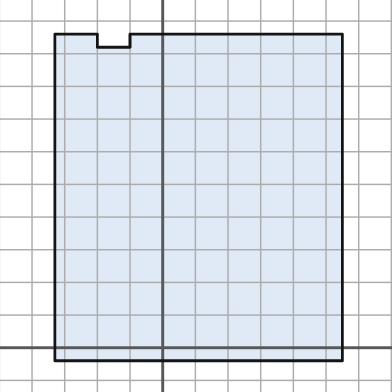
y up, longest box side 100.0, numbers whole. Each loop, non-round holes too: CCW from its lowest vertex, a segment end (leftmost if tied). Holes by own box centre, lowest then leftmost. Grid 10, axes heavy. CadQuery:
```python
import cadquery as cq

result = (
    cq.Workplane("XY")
    .moveTo(-33.0, -4.0)
    .lineTo(55.0, -4.0)
    .lineTo(55.0, 96.0)
    .lineTo(-10.0, 96.0)
    .lineTo(-10.0, 92.0)
    .lineTo(-20.0, 92.0)
    .lineTo(-20.0, 96.0)
    .lineTo(-33.0, 96.0)
    .close()
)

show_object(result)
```